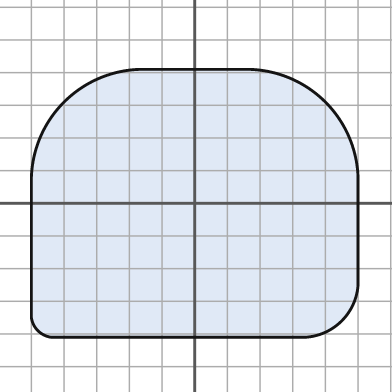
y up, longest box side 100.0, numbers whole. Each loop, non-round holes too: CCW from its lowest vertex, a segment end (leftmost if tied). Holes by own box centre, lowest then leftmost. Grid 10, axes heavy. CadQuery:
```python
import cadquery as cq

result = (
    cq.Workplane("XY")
    .moveTo(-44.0, -41.0)
    .lineTo(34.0, -41.0)
    .threePointArc((45.0, -36.0), (50.0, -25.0))
    .lineTo(50.0, 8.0)
    .threePointArc((40.0, 31.0), (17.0, 41.0))
    .lineTo(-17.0, 41.0)
    .threePointArc((-40.0, 31.0), (-50.0, 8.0))
    .lineTo(-50.0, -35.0)
    .threePointArc((-48.0, -39.0), (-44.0, -41.0))
    .close()
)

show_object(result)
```